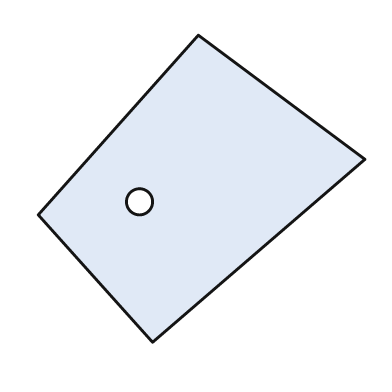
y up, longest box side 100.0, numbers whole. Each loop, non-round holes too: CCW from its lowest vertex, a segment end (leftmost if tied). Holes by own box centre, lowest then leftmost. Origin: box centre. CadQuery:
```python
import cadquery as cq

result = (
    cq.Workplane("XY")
    .moveTo(-15.0, -47.0)
    .lineTo(50.0, 9.0)
    .lineTo(-1.0, 47.0)
    .lineTo(-50.0, -8.0)
    .close()
    .moveTo(-19.0, -4.0)
    .circle(4.0)
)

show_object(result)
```